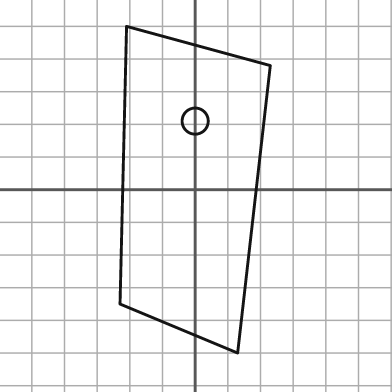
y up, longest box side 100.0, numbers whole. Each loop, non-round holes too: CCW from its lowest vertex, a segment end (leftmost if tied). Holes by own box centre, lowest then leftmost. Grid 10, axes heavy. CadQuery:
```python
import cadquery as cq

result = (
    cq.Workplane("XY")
    .moveTo(13.0, -50.0)
    .lineTo(23.0, 38.0)
    .lineTo(-21.0, 50.0)
    .lineTo(-23.0, -35.0)
    .close()
    .moveTo(0.0, 21.0)
    .circle(4.0)
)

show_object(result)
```